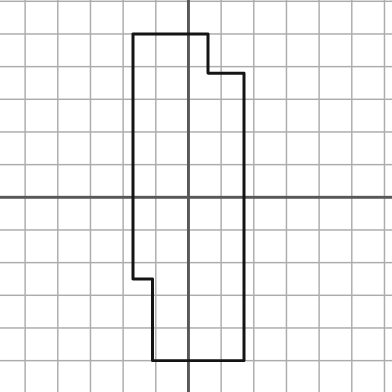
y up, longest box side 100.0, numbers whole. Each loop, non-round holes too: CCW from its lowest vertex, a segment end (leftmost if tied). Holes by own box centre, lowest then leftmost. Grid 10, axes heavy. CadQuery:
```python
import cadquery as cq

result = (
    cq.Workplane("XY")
    .moveTo(-11.0, -50.0)
    .lineTo(17.0, -50.0)
    .lineTo(17.0, 38.0)
    .lineTo(6.0, 38.0)
    .lineTo(6.0, 50.0)
    .lineTo(-17.0, 50.0)
    .lineTo(-17.0, -25.0)
    .lineTo(-11.0, -25.0)
    .close()
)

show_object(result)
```